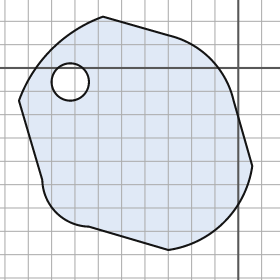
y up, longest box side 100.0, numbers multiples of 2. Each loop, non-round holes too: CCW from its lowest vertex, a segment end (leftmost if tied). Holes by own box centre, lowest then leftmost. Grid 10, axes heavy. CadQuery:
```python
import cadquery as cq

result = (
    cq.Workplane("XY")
    .moveTo(-30.0, -78.0)
    .threePointArc((-6.0, -66.0), (6.0, -42.0))
    .lineTo(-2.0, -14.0)
    .threePointArc((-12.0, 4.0), (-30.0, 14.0))
    .lineTo(-58.0, 22.0)
    .threePointArc((-80.0, 8.0), (-94.0, -14.0))
    .lineTo(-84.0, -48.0)
    .threePointArc((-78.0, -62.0), (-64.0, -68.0))
    .close()
    .moveTo(-72.0, -6.0)
    .circle(8.0)
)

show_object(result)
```